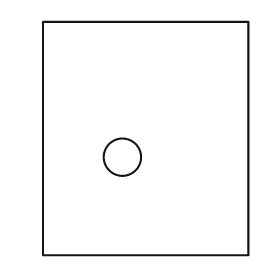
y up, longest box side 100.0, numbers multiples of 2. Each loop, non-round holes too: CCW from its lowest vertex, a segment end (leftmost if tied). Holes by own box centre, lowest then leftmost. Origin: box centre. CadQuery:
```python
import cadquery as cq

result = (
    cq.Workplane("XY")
    .moveTo(-44.0, -50.0)
    .lineTo(44.0, -50.0)
    .lineTo(44.0, 50.0)
    .lineTo(-44.0, 50.0)
    .close()
    .moveTo(-10.0, -8.0)
    .circle(8.0)
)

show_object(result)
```